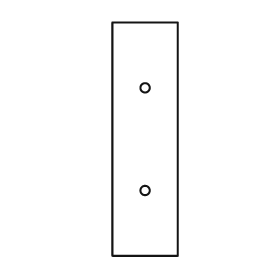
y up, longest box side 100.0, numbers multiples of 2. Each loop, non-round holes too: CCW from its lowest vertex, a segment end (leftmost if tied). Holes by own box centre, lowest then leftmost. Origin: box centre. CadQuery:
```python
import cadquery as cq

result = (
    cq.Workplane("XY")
    .moveTo(-14.0, -50.0)
    .lineTo(14.0, -50.0)
    .lineTo(14.0, 50.0)
    .lineTo(-14.0, 50.0)
    .close()
    .moveTo(0.0, -22.0)
    .circle(2.0)
    .moveTo(0.0, 22.0)
    .circle(2.0)
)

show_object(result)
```